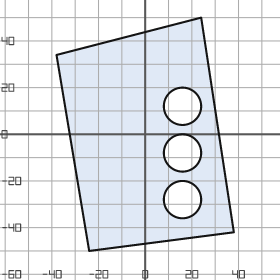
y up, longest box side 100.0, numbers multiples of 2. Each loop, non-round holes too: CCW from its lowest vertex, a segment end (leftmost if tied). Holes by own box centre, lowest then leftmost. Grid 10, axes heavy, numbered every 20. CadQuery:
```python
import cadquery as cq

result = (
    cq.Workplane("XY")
    .moveTo(-24.0, -50.0)
    .lineTo(38.0, -42.0)
    .lineTo(24.0, 50.0)
    .lineTo(-38.0, 34.0)
    .close()
    .moveTo(16.0, -28.0)
    .circle(8.0)
    .moveTo(16.0, -8.0)
    .circle(8.0)
    .moveTo(16.0, 12.0)
    .circle(8.0)
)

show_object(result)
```